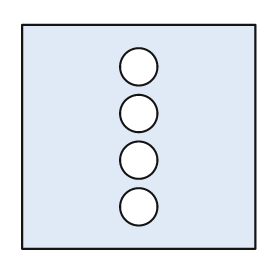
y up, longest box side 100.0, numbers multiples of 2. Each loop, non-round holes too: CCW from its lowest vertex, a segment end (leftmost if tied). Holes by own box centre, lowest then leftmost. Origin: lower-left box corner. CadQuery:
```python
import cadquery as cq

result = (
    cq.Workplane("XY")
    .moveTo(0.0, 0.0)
    .lineTo(100.0, 0.0)
    .lineTo(100.0, 96.0)
    .lineTo(0.0, 96.0)
    .close()
    .moveTo(50.0, 18.0)
    .circle(8.0)
    .moveTo(50.0, 38.0)
    .circle(8.0)
    .moveTo(50.0, 58.0)
    .circle(8.0)
    .moveTo(50.0, 78.0)
    .circle(8.0)
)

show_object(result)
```